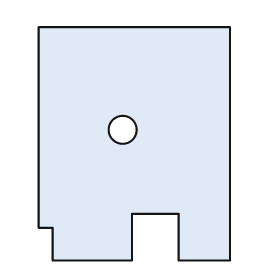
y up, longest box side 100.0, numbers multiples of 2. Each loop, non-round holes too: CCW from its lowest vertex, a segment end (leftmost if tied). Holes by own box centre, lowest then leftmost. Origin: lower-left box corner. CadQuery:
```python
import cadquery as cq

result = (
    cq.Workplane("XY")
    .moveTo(6.0, 0.0)
    .lineTo(40.0, 0.0)
    .lineTo(40.0, 20.0)
    .lineTo(60.0, 20.0)
    .lineTo(60.0, 0.0)
    .lineTo(82.0, 0.0)
    .lineTo(82.0, 100.0)
    .lineTo(0.0, 100.0)
    .lineTo(0.0, 14.0)
    .lineTo(6.0, 14.0)
    .close()
    .moveTo(36.0, 56.0)
    .circle(6.0)
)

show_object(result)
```